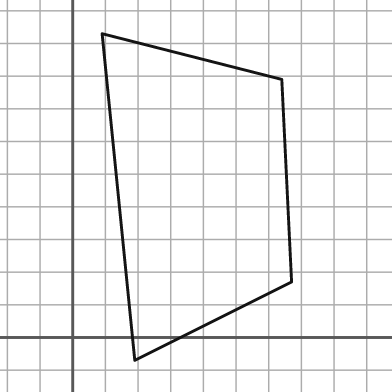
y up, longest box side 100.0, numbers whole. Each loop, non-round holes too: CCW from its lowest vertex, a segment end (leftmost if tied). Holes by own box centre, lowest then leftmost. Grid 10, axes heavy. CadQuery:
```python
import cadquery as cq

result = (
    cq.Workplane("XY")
    .moveTo(19.0, -7.0)
    .lineTo(67.0, 17.0)
    .lineTo(64.0, 79.0)
    .lineTo(9.0, 93.0)
    .close()
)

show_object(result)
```